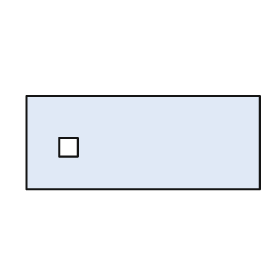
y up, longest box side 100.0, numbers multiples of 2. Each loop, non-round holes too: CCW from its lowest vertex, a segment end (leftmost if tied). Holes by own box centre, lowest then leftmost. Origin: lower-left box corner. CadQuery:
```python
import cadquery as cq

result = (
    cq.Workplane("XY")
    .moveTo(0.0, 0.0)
    .lineTo(100.0, 0.0)
    .lineTo(100.0, 40.0)
    .lineTo(0.0, 40.0)
    .close()
    .moveTo(14.0, 14.0)
    .lineTo(22.0, 14.0)
    .lineTo(22.0, 22.0)
    .lineTo(14.0, 22.0)
    .close()
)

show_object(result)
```